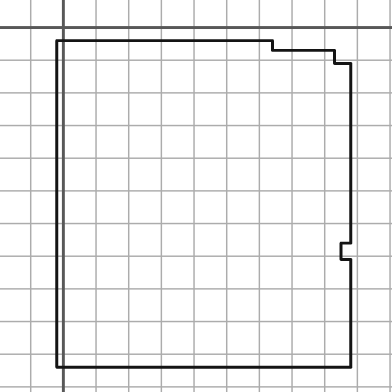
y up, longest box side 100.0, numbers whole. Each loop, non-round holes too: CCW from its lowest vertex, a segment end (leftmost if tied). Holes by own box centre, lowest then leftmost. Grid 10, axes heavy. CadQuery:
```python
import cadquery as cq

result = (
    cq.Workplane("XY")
    .moveTo(-2.0, -104.0)
    .lineTo(88.0, -104.0)
    .lineTo(88.0, -71.0)
    .lineTo(85.0, -71.0)
    .lineTo(85.0, -66.0)
    .lineTo(88.0, -66.0)
    .lineTo(88.0, -11.0)
    .lineTo(83.0, -11.0)
    .lineTo(83.0, -7.0)
    .lineTo(64.0, -7.0)
    .lineTo(64.0, -4.0)
    .lineTo(-2.0, -4.0)
    .close()
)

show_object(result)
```